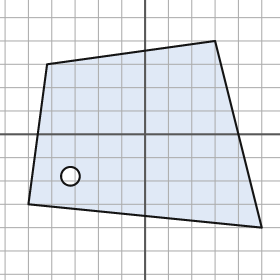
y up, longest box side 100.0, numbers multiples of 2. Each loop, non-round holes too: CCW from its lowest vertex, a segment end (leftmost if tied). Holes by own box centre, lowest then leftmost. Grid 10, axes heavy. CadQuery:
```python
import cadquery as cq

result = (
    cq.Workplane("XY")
    .moveTo(50.0, -40.0)
    .lineTo(30.0, 40.0)
    .lineTo(-42.0, 30.0)
    .lineTo(-50.0, -30.0)
    .close()
    .moveTo(-32.0, -18.0)
    .circle(4.0)
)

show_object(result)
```